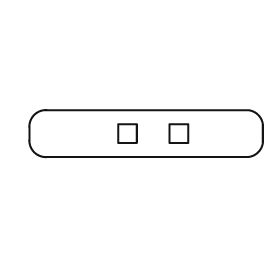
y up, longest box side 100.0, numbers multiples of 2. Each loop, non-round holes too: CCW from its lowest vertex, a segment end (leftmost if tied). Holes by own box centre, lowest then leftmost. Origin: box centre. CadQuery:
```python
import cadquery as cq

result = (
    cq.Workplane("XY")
    .moveTo(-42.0, -10.0)
    .lineTo(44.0, -10.0)
    .threePointArc((48.0, -8.0), (50.0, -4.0))
    .lineTo(50.0, 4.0)
    .threePointArc((48.0, 8.0), (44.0, 10.0))
    .lineTo(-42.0, 10.0)
    .threePointArc((-48.0, 8.0), (-50.0, 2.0))
    .lineTo(-50.0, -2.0)
    .threePointArc((-48.0, -8.0), (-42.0, -10.0))
    .close()
    .moveTo(-12.0, -4.0)
    .lineTo(-4.0, -4.0)
    .lineTo(-4.0, 4.0)
    .lineTo(-12.0, 4.0)
    .close()
    .moveTo(10.0, -4.0)
    .lineTo(18.0, -4.0)
    .lineTo(18.0, 4.0)
    .lineTo(10.0, 4.0)
    .close()
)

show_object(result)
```